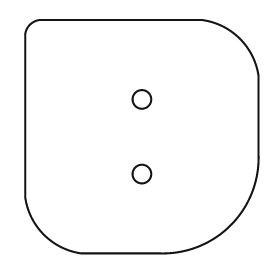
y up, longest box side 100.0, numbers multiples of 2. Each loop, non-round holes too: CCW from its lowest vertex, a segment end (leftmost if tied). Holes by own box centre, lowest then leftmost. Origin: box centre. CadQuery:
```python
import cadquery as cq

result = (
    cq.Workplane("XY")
    .moveTo(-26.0, -50.0)
    .lineTo(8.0, -50.0)
    .threePointArc((38.0, -38.0), (50.0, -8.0))
    .lineTo(50.0, 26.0)
    .threePointArc((42.0, 42.0), (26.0, 50.0))
    .lineTo(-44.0, 50.0)
    .threePointArc((-48.0, 48.0), (-50.0, 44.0))
    .lineTo(-50.0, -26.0)
    .threePointArc((-42.0, -42.0), (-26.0, -50.0))
    .close()
    .moveTo(0.0, -16.0)
    .circle(4.0)
    .moveTo(0.0, 16.0)
    .circle(4.0)
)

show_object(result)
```